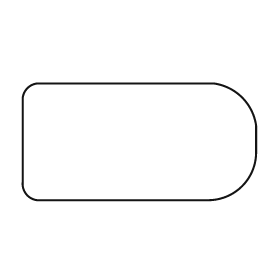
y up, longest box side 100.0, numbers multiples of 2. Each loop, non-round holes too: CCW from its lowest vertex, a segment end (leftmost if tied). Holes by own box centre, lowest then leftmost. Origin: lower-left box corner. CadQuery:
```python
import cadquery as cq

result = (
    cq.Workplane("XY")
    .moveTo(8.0, 0.0)
    .lineTo(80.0, 0.0)
    .threePointArc((94.0, 6.0), (100.0, 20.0))
    .lineTo(100.0, 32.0)
    .threePointArc((94.0, 44.0), (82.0, 50.0))
    .lineTo(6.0, 50.0)
    .threePointArc((2.0, 48.0), (0.0, 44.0))
    .lineTo(0.0, 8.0)
    .threePointArc((2.0, 2.0), (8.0, 0.0))
    .close()
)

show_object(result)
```